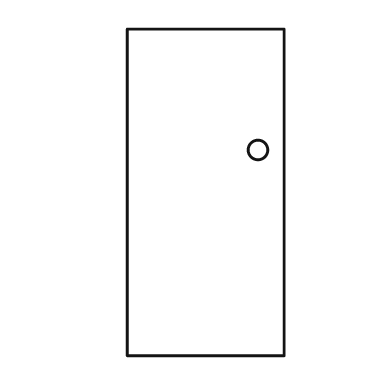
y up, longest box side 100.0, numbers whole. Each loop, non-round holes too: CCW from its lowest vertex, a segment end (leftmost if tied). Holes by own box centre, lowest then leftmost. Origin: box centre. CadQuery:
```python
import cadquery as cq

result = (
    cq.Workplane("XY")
    .moveTo(-24.0, -50.0)
    .lineTo(24.0, -50.0)
    .lineTo(24.0, 50.0)
    .lineTo(-24.0, 50.0)
    .close()
    .moveTo(16.0, 13.0)
    .circle(3.0)
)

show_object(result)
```